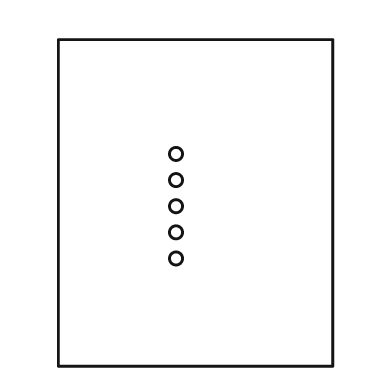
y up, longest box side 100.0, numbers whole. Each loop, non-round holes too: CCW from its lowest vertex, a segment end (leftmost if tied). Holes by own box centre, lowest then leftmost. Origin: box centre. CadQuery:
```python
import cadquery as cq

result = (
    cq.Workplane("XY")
    .moveTo(-42.0, -50.0)
    .lineTo(42.0, -50.0)
    .lineTo(42.0, 50.0)
    .lineTo(-42.0, 50.0)
    .close()
    .moveTo(-6.0, -17.0)
    .circle(2.0)
    .moveTo(-6.0, -9.0)
    .circle(2.0)
    .moveTo(-6.0, -1.0)
    .circle(2.0)
    .moveTo(-6.0, 7.0)
    .circle(2.0)
    .moveTo(-6.0, 15.0)
    .circle(2.0)
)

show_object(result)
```